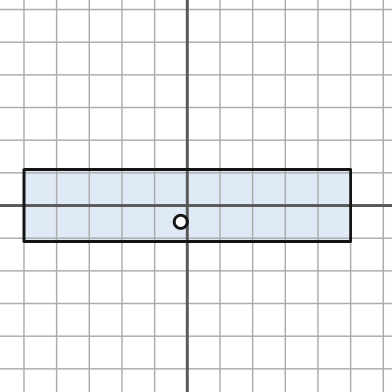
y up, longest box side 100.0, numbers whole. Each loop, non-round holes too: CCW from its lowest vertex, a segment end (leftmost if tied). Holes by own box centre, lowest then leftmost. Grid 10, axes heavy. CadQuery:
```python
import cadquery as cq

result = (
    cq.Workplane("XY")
    .moveTo(-50.0, -11.0)
    .lineTo(50.0, -11.0)
    .lineTo(50.0, 11.0)
    .lineTo(-50.0, 11.0)
    .close()
    .moveTo(-2.0, -5.0)
    .circle(2.0)
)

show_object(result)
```